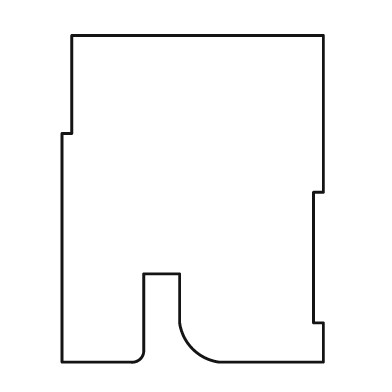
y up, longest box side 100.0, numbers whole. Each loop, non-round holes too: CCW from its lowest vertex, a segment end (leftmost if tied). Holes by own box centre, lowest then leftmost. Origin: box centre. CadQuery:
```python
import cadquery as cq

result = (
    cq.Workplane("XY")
    .moveTo(-40.0, -50.0)
    .lineTo(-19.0, -50.0)
    .threePointArc((-16.0, -49.0), (-15.0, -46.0))
    .lineTo(-15.0, -23.0)
    .lineTo(-4.0, -23.0)
    .lineTo(-4.0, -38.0)
    .threePointArc((0.0, -46.0), (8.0, -50.0))
    .lineTo(40.0, -50.0)
    .lineTo(40.0, -38.0)
    .lineTo(37.0, -38.0)
    .lineTo(37.0, 2.0)
    .lineTo(40.0, 2.0)
    .lineTo(40.0, 50.0)
    .lineTo(-37.0, 50.0)
    .lineTo(-37.0, 20.0)
    .lineTo(-40.0, 20.0)
    .close()
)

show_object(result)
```